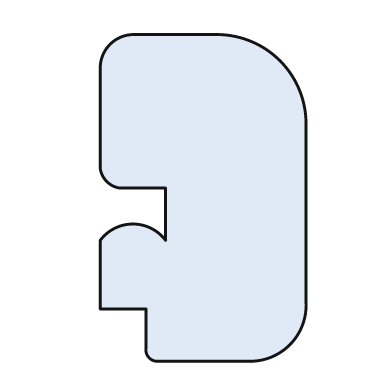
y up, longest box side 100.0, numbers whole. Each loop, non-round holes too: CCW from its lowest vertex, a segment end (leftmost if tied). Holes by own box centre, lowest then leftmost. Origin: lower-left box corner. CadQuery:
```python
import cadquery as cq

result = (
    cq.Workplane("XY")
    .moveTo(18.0, 0.0)
    .lineTo(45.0, 0.0)
    .threePointArc((58.0, 5.0), (63.0, 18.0))
    .lineTo(63.0, 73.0)
    .threePointArc((55.0, 92.0), (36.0, 100.0))
    .lineTo(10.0, 100.0)
    .threePointArc((3.0, 97.0), (0.0, 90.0))
    .lineTo(0.0, 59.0)
    .threePointArc((2.0, 55.0), (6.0, 53.0))
    .lineTo(20.0, 53.0)
    .lineTo(20.0, 37.0)
    .threePointArc((10.0, 42.0), (0.0, 37.0))
    .lineTo(0.0, 16.0)
    .lineTo(14.0, 16.0)
    .lineTo(14.0, 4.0)
    .threePointArc((15.0, 1.0), (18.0, 0.0))
    .close()
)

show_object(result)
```